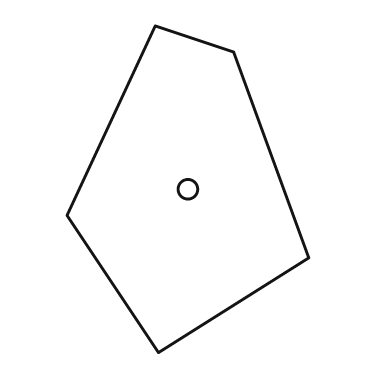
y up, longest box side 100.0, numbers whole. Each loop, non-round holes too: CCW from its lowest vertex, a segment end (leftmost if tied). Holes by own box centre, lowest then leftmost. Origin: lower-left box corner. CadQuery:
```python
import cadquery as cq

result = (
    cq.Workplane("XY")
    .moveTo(28.0, 0.0)
    .lineTo(74.0, 29.0)
    .lineTo(51.0, 92.0)
    .lineTo(27.0, 100.0)
    .lineTo(0.0, 42.0)
    .close()
    .moveTo(37.0, 50.0)
    .circle(3.0)
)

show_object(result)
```